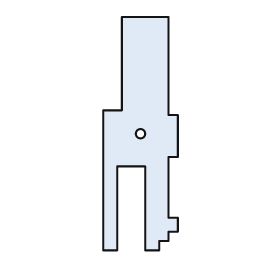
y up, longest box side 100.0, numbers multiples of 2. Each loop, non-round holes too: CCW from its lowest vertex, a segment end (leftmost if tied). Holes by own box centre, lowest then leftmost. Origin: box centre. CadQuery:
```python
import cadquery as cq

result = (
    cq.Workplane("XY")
    .moveTo(-16.0, -50.0)
    .lineTo(-10.0, -50.0)
    .lineTo(-10.0, -14.0)
    .lineTo(2.0, -14.0)
    .lineTo(2.0, -50.0)
    .lineTo(8.0, -50.0)
    .lineTo(8.0, -46.0)
    .lineTo(12.0, -46.0)
    .lineTo(12.0, -42.0)
    .lineTo(16.0, -42.0)
    .lineTo(16.0, -36.0)
    .lineTo(12.0, -36.0)
    .lineTo(12.0, -10.0)
    .lineTo(16.0, -10.0)
    .lineTo(16.0, 8.0)
    .lineTo(12.0, 8.0)
    .lineTo(12.0, 50.0)
    .lineTo(-8.0, 50.0)
    .lineTo(-8.0, 10.0)
    .lineTo(-16.0, 10.0)
    .close()
    .moveTo(0.0, 0.0)
    .circle(2.0)
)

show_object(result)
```